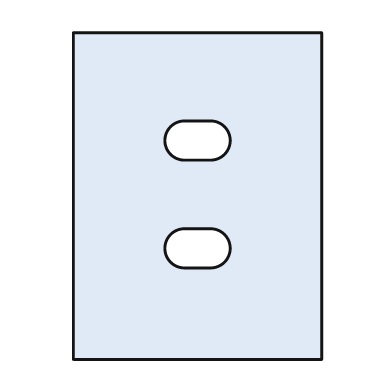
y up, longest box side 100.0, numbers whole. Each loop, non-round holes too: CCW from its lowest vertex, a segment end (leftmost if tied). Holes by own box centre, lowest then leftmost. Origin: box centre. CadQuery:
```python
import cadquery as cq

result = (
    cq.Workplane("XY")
    .moveTo(-38.0, -50.0)
    .lineTo(38.0, -50.0)
    .lineTo(38.0, 50.0)
    .lineTo(-38.0, 50.0)
    .close()
    .moveTo(-4.0, -22.0)
    .lineTo(4.0, -22.0)
    .threePointArc((10.0, -16.0), (4.0, -10.0))
    .lineTo(-4.0, -10.0)
    .threePointArc((-10.0, -16.0), (-4.0, -22.0))
    .close()
    .moveTo(-4.0, 11.0)
    .lineTo(4.0, 11.0)
    .threePointArc((10.0, 17.0), (4.0, 23.0))
    .lineTo(-4.0, 23.0)
    .threePointArc((-10.0, 17.0), (-4.0, 11.0))
    .close()
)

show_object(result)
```